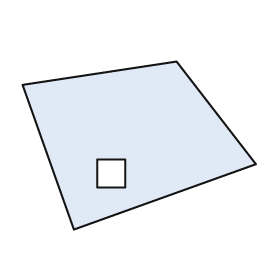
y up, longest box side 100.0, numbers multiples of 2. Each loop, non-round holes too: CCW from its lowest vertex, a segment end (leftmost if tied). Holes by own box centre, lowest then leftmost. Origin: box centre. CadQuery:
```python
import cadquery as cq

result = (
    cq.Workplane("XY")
    .moveTo(-28.0, -36.0)
    .lineTo(50.0, -8.0)
    .lineTo(16.0, 36.0)
    .lineTo(-50.0, 26.0)
    .close()
    .moveTo(-18.0, -18.0)
    .lineTo(-6.0, -18.0)
    .lineTo(-6.0, -6.0)
    .lineTo(-18.0, -6.0)
    .close()
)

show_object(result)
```